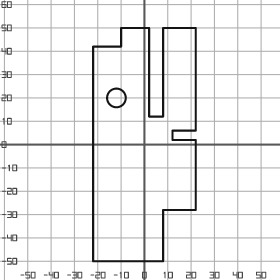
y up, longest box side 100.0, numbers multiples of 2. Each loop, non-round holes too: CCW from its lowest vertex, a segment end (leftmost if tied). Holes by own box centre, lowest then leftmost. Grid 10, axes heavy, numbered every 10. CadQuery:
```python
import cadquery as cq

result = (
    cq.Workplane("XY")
    .moveTo(-22.0, -50.0)
    .lineTo(8.0, -50.0)
    .lineTo(8.0, -28.0)
    .lineTo(22.0, -28.0)
    .lineTo(22.0, 2.0)
    .lineTo(12.0, 2.0)
    .lineTo(12.0, 6.0)
    .lineTo(22.0, 6.0)
    .lineTo(22.0, 50.0)
    .lineTo(8.0, 50.0)
    .lineTo(8.0, 12.0)
    .lineTo(2.0, 12.0)
    .lineTo(2.0, 50.0)
    .lineTo(-10.0, 50.0)
    .lineTo(-10.0, 42.0)
    .lineTo(-22.0, 42.0)
    .close()
    .moveTo(-12.0, 20.0)
    .circle(4.0)
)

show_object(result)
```